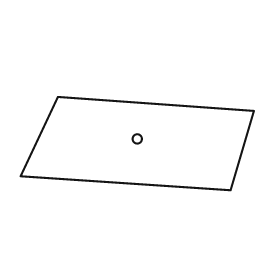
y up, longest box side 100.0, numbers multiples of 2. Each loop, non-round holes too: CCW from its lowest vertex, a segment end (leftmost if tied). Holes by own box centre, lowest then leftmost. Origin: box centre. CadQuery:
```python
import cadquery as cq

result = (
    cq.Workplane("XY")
    .moveTo(40.0, -20.0)
    .lineTo(50.0, 14.0)
    .lineTo(-34.0, 20.0)
    .lineTo(-50.0, -14.0)
    .close()
    .moveTo(0.0, 2.0)
    .circle(2.0)
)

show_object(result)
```